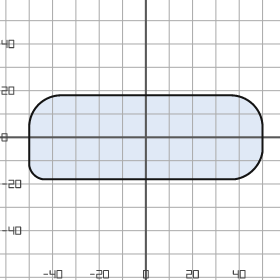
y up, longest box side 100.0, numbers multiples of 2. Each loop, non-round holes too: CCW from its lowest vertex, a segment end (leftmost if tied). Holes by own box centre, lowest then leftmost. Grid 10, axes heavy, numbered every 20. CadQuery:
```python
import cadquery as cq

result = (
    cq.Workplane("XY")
    .moveTo(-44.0, -18.0)
    .lineTo(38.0, -18.0)
    .threePointArc((46.0, -14.0), (50.0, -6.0))
    .lineTo(50.0, 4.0)
    .threePointArc((46.0, 14.0), (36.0, 18.0))
    .lineTo(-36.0, 18.0)
    .threePointArc((-46.0, 14.0), (-50.0, 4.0))
    .lineTo(-50.0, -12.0)
    .threePointArc((-48.0, -16.0), (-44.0, -18.0))
    .close()
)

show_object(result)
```